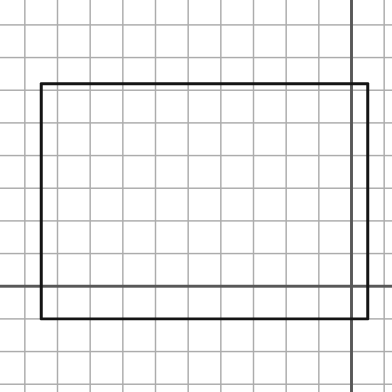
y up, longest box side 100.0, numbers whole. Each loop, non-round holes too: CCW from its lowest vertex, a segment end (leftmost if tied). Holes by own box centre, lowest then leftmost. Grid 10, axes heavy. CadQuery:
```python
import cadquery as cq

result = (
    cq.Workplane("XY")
    .moveTo(-95.0, -10.0)
    .lineTo(5.0, -10.0)
    .lineTo(5.0, 62.0)
    .lineTo(-95.0, 62.0)
    .close()
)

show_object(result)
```